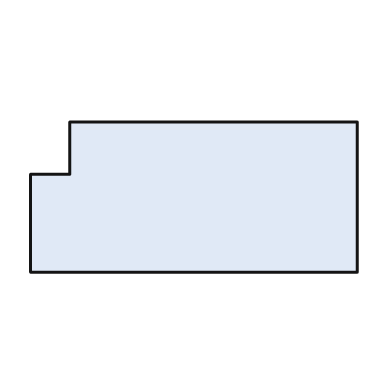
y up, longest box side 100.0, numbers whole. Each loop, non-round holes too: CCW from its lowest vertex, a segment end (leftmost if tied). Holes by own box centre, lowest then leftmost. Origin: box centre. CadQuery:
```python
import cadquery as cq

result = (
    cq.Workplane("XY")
    .moveTo(-50.0, -23.0)
    .lineTo(50.0, -23.0)
    .lineTo(50.0, 23.0)
    .lineTo(-38.0, 23.0)
    .lineTo(-38.0, 7.0)
    .lineTo(-50.0, 7.0)
    .close()
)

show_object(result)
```